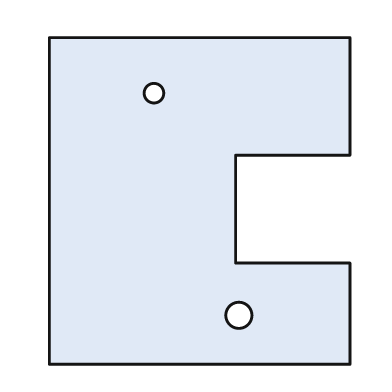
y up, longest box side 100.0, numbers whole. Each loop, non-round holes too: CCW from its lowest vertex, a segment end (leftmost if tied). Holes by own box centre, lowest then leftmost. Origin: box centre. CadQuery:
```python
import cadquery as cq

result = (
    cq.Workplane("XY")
    .moveTo(-46.0, -50.0)
    .lineTo(46.0, -50.0)
    .lineTo(46.0, -19.0)
    .lineTo(11.0, -19.0)
    .lineTo(11.0, 14.0)
    .lineTo(46.0, 14.0)
    .lineTo(46.0, 50.0)
    .lineTo(-46.0, 50.0)
    .close()
    .moveTo(12.0, -35.0)
    .circle(4.0)
    .moveTo(-14.0, 33.0)
    .circle(3.0)
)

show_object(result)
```